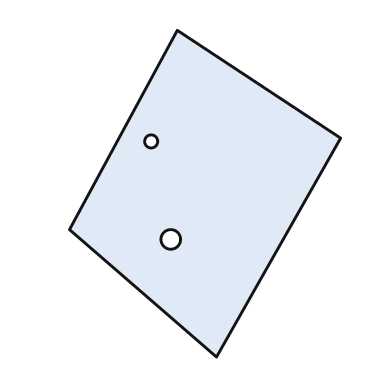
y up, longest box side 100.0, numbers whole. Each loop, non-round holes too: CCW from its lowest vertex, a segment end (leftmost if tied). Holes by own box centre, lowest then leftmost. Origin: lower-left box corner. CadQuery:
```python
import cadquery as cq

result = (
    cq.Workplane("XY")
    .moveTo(45.0, 0.0)
    .lineTo(83.0, 67.0)
    .lineTo(33.0, 100.0)
    .lineTo(0.0, 39.0)
    .close()
    .moveTo(31.0, 36.0)
    .circle(3.0)
    .moveTo(25.0, 66.0)
    .circle(2.0)
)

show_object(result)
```